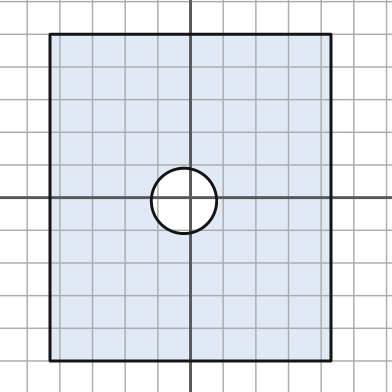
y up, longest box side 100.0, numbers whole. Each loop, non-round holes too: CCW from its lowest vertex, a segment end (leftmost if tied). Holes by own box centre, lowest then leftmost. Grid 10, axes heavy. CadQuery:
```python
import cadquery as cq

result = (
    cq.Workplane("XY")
    .moveTo(-43.0, -50.0)
    .lineTo(43.0, -50.0)
    .lineTo(43.0, 50.0)
    .lineTo(-43.0, 50.0)
    .close()
    .moveTo(-2.0, -1.0)
    .circle(10.0)
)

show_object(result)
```